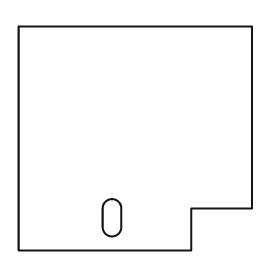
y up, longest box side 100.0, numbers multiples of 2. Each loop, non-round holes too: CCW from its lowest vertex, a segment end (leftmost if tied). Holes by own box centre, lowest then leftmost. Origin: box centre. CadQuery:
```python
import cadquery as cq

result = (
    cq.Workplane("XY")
    .moveTo(-50.0, -48.0)
    .lineTo(24.0, -48.0)
    .lineTo(24.0, -30.0)
    .lineTo(50.0, -30.0)
    .lineTo(50.0, 48.0)
    .lineTo(-50.0, 48.0)
    .close()
    .moveTo(-14.0, -38.0)
    .threePointArc((-10.0, -42.0), (-6.0, -38.0))
    .lineTo(-6.0, -30.0)
    .threePointArc((-10.0, -26.0), (-14.0, -30.0))
    .close()
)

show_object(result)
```